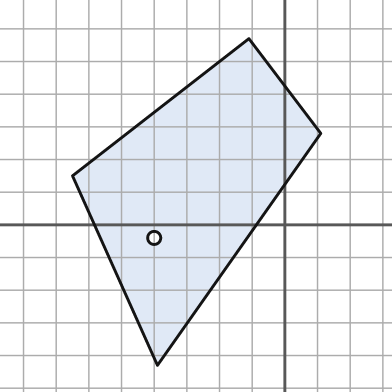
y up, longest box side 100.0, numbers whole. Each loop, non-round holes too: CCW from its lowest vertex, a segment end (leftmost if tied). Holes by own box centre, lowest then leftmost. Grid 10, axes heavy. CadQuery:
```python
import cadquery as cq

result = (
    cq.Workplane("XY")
    .moveTo(-39.0, -43.0)
    .lineTo(11.0, 28.0)
    .lineTo(-11.0, 57.0)
    .lineTo(-65.0, 15.0)
    .close()
    .moveTo(-40.0, -4.0)
    .circle(2.0)
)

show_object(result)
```